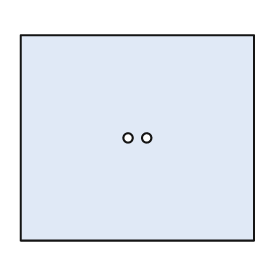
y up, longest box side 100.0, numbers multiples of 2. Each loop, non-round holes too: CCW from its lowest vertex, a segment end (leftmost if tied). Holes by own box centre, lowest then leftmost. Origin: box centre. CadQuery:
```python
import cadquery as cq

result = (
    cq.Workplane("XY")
    .moveTo(-50.0, -44.0)
    .lineTo(50.0, -44.0)
    .lineTo(50.0, 44.0)
    .lineTo(-50.0, 44.0)
    .close()
    .moveTo(-4.0, 0.0)
    .circle(2.0)
    .moveTo(4.0, 0.0)
    .circle(2.0)
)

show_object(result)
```